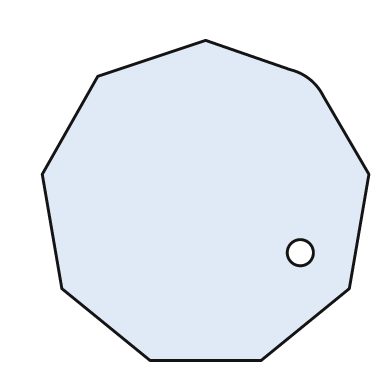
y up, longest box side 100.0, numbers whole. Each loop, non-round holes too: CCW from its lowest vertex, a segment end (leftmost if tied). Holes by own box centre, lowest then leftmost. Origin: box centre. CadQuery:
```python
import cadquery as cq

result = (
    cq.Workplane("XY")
    .moveTo(-17.0, -49.0)
    .lineTo(17.0, -49.0)
    .lineTo(44.0, -27.0)
    .lineTo(50.0, 8.0)
    .lineTo(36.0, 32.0)
    .threePointArc((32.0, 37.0), (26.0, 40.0))
    .lineTo(0.0, 49.0)
    .lineTo(-33.0, 38.0)
    .lineTo(-50.0, 8.0)
    .lineTo(-44.0, -27.0)
    .close()
    .moveTo(29.0, -16.0)
    .circle(4.0)
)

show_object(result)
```